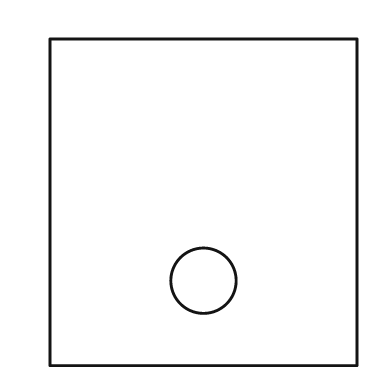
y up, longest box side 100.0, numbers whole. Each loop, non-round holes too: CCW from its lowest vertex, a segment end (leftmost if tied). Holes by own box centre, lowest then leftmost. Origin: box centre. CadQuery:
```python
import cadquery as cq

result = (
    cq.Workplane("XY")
    .moveTo(-47.0, -50.0)
    .lineTo(47.0, -50.0)
    .lineTo(47.0, 50.0)
    .lineTo(-47.0, 50.0)
    .close()
    .moveTo(0.0, -24.0)
    .circle(10.0)
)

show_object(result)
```